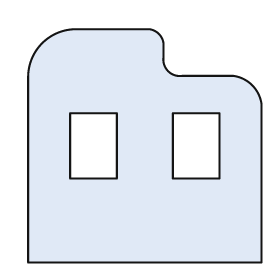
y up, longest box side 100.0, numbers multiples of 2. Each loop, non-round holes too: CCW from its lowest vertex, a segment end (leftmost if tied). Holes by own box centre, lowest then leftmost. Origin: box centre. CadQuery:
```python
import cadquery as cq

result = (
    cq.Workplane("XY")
    .moveTo(-50.0, -50.0)
    .lineTo(50.0, -50.0)
    .lineTo(50.0, 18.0)
    .threePointArc((46.0, 26.0), (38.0, 30.0))
    .lineTo(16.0, 30.0)
    .threePointArc((10.0, 32.0), (8.0, 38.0))
    .lineTo(8.0, 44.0)
    .threePointArc((6.0, 48.0), (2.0, 50.0))
    .lineTo(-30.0, 50.0)
    .threePointArc((-44.0, 44.0), (-50.0, 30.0))
    .close()
    .moveTo(-32.0, -14.0)
    .lineTo(-12.0, -14.0)
    .lineTo(-12.0, 14.0)
    .lineTo(-32.0, 14.0)
    .close()
    .moveTo(12.0, -14.0)
    .lineTo(32.0, -14.0)
    .lineTo(32.0, 14.0)
    .lineTo(12.0, 14.0)
    .close()
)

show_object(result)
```